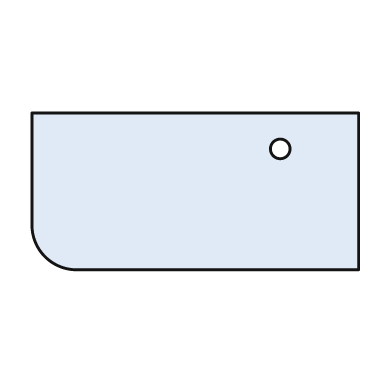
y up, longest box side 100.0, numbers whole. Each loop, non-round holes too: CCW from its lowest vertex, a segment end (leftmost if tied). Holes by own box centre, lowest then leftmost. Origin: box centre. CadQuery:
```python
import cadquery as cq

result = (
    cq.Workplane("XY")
    .moveTo(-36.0, -24.0)
    .lineTo(50.0, -24.0)
    .lineTo(50.0, 24.0)
    .lineTo(-50.0, 24.0)
    .lineTo(-50.0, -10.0)
    .threePointArc((-46.0, -20.0), (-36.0, -24.0))
    .close()
    .moveTo(26.0, 13.0)
    .circle(3.0)
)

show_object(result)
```